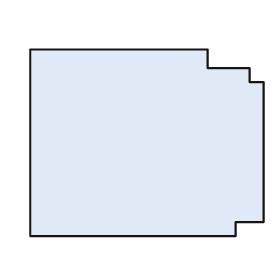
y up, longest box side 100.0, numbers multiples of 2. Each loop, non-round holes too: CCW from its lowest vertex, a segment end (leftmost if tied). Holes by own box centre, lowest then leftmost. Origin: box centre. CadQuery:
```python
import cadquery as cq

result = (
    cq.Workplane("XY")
    .moveTo(-50.0, -40.0)
    .lineTo(38.0, -40.0)
    .lineTo(38.0, -34.0)
    .lineTo(50.0, -34.0)
    .lineTo(50.0, 26.0)
    .lineTo(44.0, 26.0)
    .lineTo(44.0, 32.0)
    .lineTo(26.0, 32.0)
    .lineTo(26.0, 40.0)
    .lineTo(-50.0, 40.0)
    .close()
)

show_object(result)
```